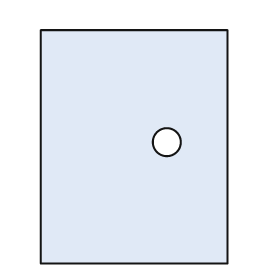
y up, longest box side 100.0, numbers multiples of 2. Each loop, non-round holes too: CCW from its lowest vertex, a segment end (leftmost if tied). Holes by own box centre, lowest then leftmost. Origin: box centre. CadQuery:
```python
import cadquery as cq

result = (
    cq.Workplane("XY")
    .moveTo(-40.0, -50.0)
    .lineTo(40.0, -50.0)
    .lineTo(40.0, 50.0)
    .lineTo(-40.0, 50.0)
    .close()
    .moveTo(14.0, 2.0)
    .circle(6.0)
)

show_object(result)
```